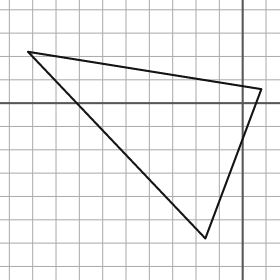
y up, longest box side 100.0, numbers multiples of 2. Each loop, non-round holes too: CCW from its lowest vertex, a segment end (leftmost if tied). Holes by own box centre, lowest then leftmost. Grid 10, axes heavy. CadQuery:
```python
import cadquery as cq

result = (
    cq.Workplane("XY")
    .moveTo(-16.0, -58.0)
    .lineTo(8.0, 6.0)
    .lineTo(-92.0, 22.0)
    .close()
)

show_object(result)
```